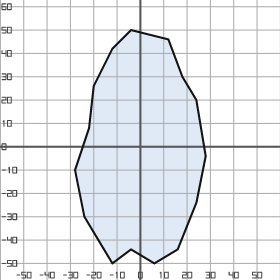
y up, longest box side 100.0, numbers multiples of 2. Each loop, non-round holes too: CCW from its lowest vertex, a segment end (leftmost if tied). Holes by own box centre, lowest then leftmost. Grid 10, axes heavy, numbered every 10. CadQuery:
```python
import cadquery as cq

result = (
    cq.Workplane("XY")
    .moveTo(-12.0, -50.0)
    .lineTo(-4.0, -44.0)
    .lineTo(6.0, -50.0)
    .lineTo(16.0, -44.0)
    .lineTo(24.0, -24.0)
    .lineTo(28.0, -4.0)
    .lineTo(24.0, 20.0)
    .lineTo(18.0, 30.0)
    .lineTo(12.0, 46.0)
    .lineTo(-4.0, 50.0)
    .lineTo(-12.0, 42.0)
    .lineTo(-20.0, 26.0)
    .lineTo(-22.0, 8.0)
    .lineTo(-28.0, -10.0)
    .lineTo(-24.0, -30.0)
    .close()
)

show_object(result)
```